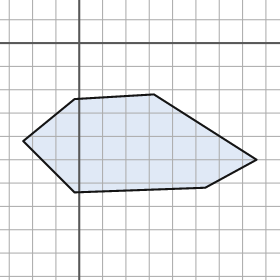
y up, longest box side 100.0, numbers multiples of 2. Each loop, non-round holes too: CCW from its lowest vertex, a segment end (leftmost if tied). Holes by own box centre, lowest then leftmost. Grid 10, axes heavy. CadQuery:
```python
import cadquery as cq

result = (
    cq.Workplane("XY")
    .moveTo(-2.0, -64.0)
    .lineTo(54.0, -62.0)
    .lineTo(76.0, -50.0)
    .lineTo(32.0, -22.0)
    .lineTo(-2.0, -24.0)
    .lineTo(-24.0, -42.0)
    .close()
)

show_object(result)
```